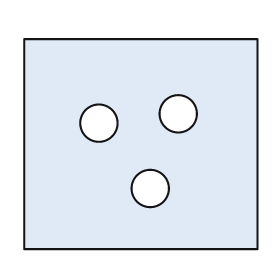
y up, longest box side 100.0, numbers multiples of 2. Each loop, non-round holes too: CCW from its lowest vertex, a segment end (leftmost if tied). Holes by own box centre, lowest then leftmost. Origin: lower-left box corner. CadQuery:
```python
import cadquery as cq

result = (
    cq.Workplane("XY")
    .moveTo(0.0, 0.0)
    .lineTo(100.0, 0.0)
    .lineTo(100.0, 90.0)
    .lineTo(0.0, 90.0)
    .close()
    .moveTo(54.0, 26.0)
    .circle(8.0)
    .moveTo(32.0, 54.0)
    .circle(8.0)
    .moveTo(66.0, 58.0)
    .circle(8.0)
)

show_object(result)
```